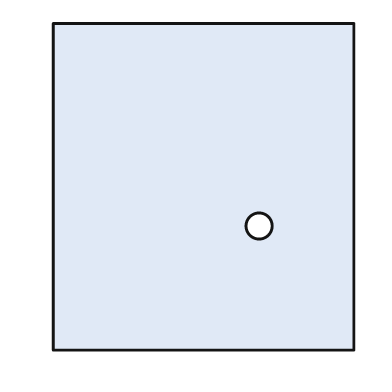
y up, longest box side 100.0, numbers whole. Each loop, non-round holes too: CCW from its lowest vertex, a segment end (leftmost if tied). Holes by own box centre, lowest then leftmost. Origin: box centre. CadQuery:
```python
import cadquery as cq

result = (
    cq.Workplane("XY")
    .moveTo(-46.0, -50.0)
    .lineTo(46.0, -50.0)
    .lineTo(46.0, 50.0)
    .lineTo(-46.0, 50.0)
    .close()
    .moveTo(17.0, -12.0)
    .circle(4.0)
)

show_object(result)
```